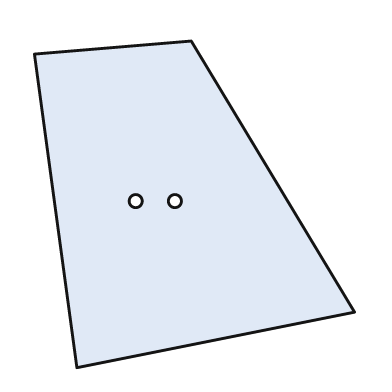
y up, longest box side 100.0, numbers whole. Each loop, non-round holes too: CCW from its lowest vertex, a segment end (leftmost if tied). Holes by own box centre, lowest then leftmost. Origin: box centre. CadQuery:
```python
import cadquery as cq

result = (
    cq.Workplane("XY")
    .moveTo(-36.0, -50.0)
    .lineTo(49.0, -33.0)
    .lineTo(-1.0, 50.0)
    .lineTo(-49.0, 46.0)
    .close()
    .moveTo(-18.0, 1.0)
    .circle(2.0)
    .moveTo(-6.0, 1.0)
    .circle(2.0)
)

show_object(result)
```